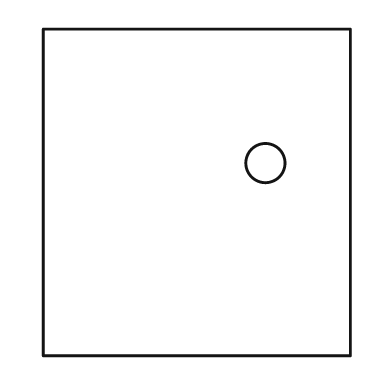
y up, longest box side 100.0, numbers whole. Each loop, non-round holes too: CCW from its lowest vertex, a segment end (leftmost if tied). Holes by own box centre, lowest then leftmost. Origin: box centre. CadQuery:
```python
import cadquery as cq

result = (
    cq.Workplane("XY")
    .moveTo(-47.0, -50.0)
    .lineTo(47.0, -50.0)
    .lineTo(47.0, 50.0)
    .lineTo(-47.0, 50.0)
    .close()
    .moveTo(21.0, 9.0)
    .circle(6.0)
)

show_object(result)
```